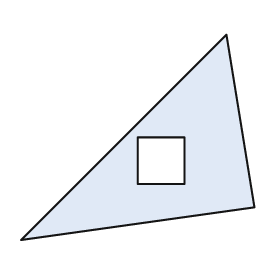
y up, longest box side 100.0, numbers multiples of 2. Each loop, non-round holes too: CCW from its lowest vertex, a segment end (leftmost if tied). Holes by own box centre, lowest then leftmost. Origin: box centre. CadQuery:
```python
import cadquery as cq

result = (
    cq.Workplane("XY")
    .moveTo(-50.0, -44.0)
    .lineTo(50.0, -30.0)
    .lineTo(38.0, 44.0)
    .close()
    .moveTo(0.0, -20.0)
    .lineTo(20.0, -20.0)
    .lineTo(20.0, 0.0)
    .lineTo(0.0, 0.0)
    .close()
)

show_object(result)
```